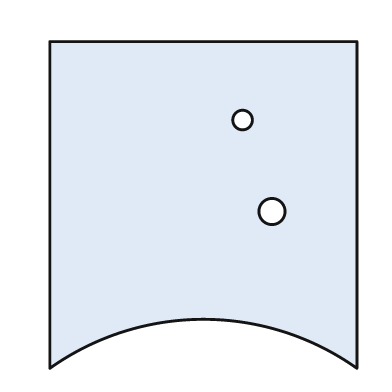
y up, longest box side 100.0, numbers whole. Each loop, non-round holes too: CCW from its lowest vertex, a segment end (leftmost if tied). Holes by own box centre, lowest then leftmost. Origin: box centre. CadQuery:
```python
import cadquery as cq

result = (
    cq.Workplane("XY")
    .moveTo(-47.0, -50.0)
    .threePointArc((0.0, -35.0), (47.0, -50.0))
    .lineTo(47.0, 50.0)
    .lineTo(-47.0, 50.0)
    .close()
    .moveTo(21.0, -2.0)
    .circle(4.0)
    .moveTo(12.0, 26.0)
    .circle(3.0)
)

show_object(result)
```